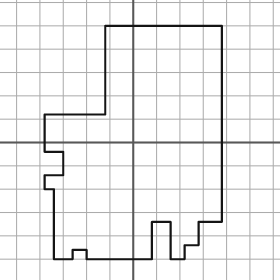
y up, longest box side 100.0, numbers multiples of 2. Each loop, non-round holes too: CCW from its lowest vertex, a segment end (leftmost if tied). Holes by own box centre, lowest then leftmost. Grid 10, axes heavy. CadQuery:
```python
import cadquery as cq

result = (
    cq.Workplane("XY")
    .moveTo(-34.0, -50.0)
    .lineTo(-26.0, -50.0)
    .lineTo(-26.0, -46.0)
    .lineTo(-20.0, -46.0)
    .lineTo(-20.0, -50.0)
    .lineTo(8.0, -50.0)
    .lineTo(8.0, -34.0)
    .lineTo(16.0, -34.0)
    .lineTo(16.0, -50.0)
    .lineTo(22.0, -50.0)
    .lineTo(22.0, -44.0)
    .lineTo(28.0, -44.0)
    .lineTo(28.0, -34.0)
    .lineTo(38.0, -34.0)
    .lineTo(38.0, 50.0)
    .lineTo(-12.0, 50.0)
    .lineTo(-12.0, 12.0)
    .lineTo(-38.0, 12.0)
    .lineTo(-38.0, -4.0)
    .lineTo(-30.0, -4.0)
    .lineTo(-30.0, -14.0)
    .lineTo(-38.0, -14.0)
    .lineTo(-38.0, -20.0)
    .lineTo(-34.0, -20.0)
    .close()
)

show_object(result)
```